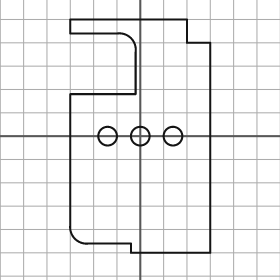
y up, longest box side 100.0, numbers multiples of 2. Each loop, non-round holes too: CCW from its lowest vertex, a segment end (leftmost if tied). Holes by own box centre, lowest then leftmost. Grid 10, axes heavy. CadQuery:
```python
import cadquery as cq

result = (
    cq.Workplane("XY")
    .moveTo(-4.0, -50.0)
    .lineTo(30.0, -50.0)
    .lineTo(30.0, 40.0)
    .lineTo(20.0, 40.0)
    .lineTo(20.0, 50.0)
    .lineTo(-30.0, 50.0)
    .lineTo(-30.0, 44.0)
    .lineTo(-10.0, 44.0)
    .threePointArc((-4.0, 42.0), (-2.0, 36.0))
    .lineTo(-2.0, 18.0)
    .lineTo(-30.0, 18.0)
    .lineTo(-30.0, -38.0)
    .threePointArc((-28.0, -44.0), (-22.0, -46.0))
    .lineTo(-4.0, -46.0)
    .close()
    .moveTo(-14.0, 0.0)
    .circle(4.0)
    .moveTo(0.0, 0.0)
    .circle(4.0)
    .moveTo(14.0, 0.0)
    .circle(4.0)
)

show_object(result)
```